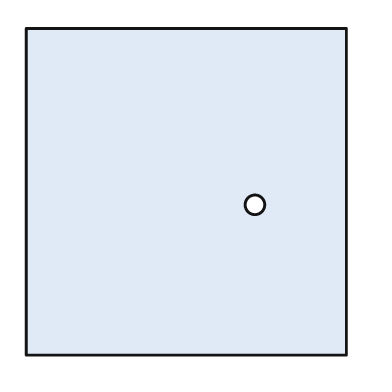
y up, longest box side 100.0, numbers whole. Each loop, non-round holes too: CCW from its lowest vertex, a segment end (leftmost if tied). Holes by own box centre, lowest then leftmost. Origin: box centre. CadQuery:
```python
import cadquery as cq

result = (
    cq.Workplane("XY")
    .moveTo(-49.0, -50.0)
    .lineTo(49.0, -50.0)
    .lineTo(49.0, 50.0)
    .lineTo(-49.0, 50.0)
    .close()
    .moveTo(21.0, -4.0)
    .circle(3.0)
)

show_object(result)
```